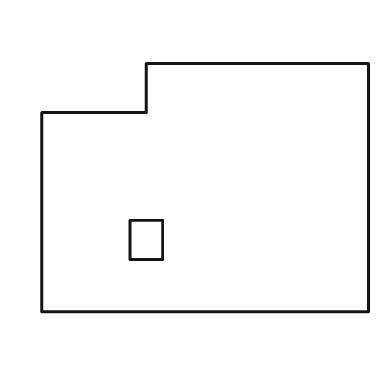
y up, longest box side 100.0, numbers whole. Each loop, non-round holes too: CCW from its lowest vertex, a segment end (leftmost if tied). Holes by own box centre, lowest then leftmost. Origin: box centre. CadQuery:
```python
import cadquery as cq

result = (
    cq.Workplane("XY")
    .moveTo(-50.0, -38.0)
    .lineTo(50.0, -38.0)
    .lineTo(50.0, 38.0)
    .lineTo(-18.0, 38.0)
    .lineTo(-18.0, 23.0)
    .lineTo(-50.0, 23.0)
    .close()
    .moveTo(-23.0, -22.0)
    .lineTo(-13.0, -22.0)
    .lineTo(-13.0, -10.0)
    .lineTo(-23.0, -10.0)
    .close()
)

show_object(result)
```